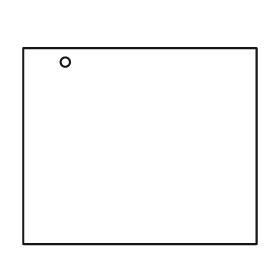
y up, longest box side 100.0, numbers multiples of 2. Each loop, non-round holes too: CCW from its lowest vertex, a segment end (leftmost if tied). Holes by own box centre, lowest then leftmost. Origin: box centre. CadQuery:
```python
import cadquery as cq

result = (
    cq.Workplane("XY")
    .moveTo(-50.0, -42.0)
    .lineTo(50.0, -42.0)
    .lineTo(50.0, 42.0)
    .lineTo(-50.0, 42.0)
    .close()
    .moveTo(-32.0, 36.0)
    .circle(2.0)
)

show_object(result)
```